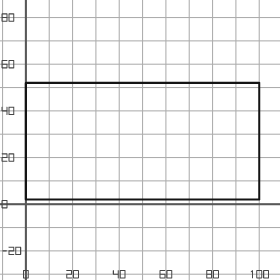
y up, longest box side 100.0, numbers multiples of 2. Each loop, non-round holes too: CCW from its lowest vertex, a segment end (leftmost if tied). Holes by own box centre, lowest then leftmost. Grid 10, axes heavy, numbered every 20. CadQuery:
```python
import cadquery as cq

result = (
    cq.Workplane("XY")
    .moveTo(0.0, 2.0)
    .lineTo(100.0, 2.0)
    .lineTo(100.0, 52.0)
    .lineTo(0.0, 52.0)
    .close()
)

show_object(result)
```